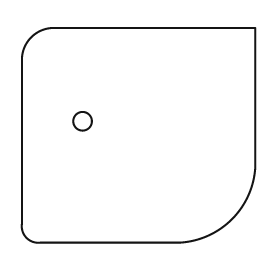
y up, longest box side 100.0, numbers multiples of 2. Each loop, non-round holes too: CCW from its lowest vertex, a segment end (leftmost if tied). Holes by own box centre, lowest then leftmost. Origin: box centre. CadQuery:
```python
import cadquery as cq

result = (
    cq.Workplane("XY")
    .moveTo(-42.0, -46.0)
    .lineTo(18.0, -46.0)
    .threePointArc((40.0, -36.0), (50.0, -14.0))
    .lineTo(50.0, 46.0)
    .lineTo(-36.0, 46.0)
    .threePointArc((-46.0, 42.0), (-50.0, 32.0))
    .lineTo(-50.0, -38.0)
    .threePointArc((-48.0, -44.0), (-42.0, -46.0))
    .close()
    .moveTo(-24.0, 6.0)
    .circle(4.0)
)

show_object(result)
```